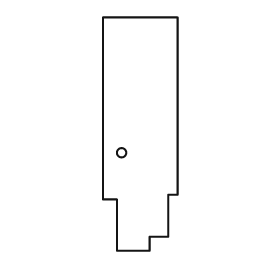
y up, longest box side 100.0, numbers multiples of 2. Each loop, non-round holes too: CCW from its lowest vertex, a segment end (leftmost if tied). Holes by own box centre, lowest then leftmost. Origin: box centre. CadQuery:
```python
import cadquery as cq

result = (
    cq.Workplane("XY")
    .moveTo(-10.0, -50.0)
    .lineTo(4.0, -50.0)
    .lineTo(4.0, -44.0)
    .lineTo(12.0, -44.0)
    .lineTo(12.0, -26.0)
    .lineTo(16.0, -26.0)
    .lineTo(16.0, 50.0)
    .lineTo(-16.0, 50.0)
    .lineTo(-16.0, -28.0)
    .lineTo(-10.0, -28.0)
    .close()
    .moveTo(-8.0, -8.0)
    .circle(2.0)
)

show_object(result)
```